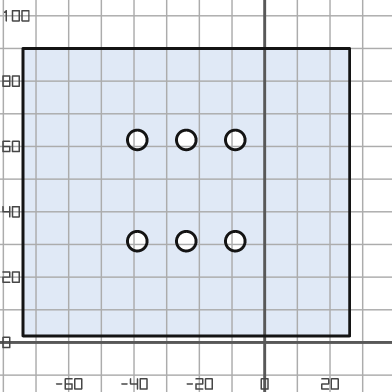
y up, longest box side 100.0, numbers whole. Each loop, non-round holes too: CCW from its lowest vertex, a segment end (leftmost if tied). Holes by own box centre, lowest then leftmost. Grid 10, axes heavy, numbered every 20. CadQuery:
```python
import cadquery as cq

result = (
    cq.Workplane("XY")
    .moveTo(-74.0, 2.0)
    .lineTo(26.0, 2.0)
    .lineTo(26.0, 90.0)
    .lineTo(-74.0, 90.0)
    .close()
    .moveTo(-39.0, 31.0)
    .circle(3.0)
    .moveTo(-24.0, 31.0)
    .circle(3.0)
    .moveTo(-9.0, 31.0)
    .circle(3.0)
    .moveTo(-39.0, 62.0)
    .circle(3.0)
    .moveTo(-24.0, 62.0)
    .circle(3.0)
    .moveTo(-9.0, 62.0)
    .circle(3.0)
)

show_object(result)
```